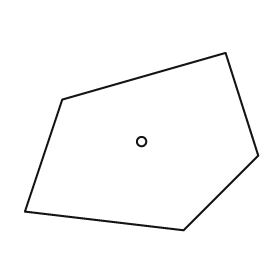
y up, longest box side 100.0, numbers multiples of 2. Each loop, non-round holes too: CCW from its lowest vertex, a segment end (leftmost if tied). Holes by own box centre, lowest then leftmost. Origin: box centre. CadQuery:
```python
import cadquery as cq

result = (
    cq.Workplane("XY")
    .moveTo(18.0, -38.0)
    .lineTo(50.0, -6.0)
    .lineTo(36.0, 38.0)
    .lineTo(-34.0, 18.0)
    .lineTo(-50.0, -30.0)
    .close()
    .moveTo(0.0, 0.0)
    .circle(2.0)
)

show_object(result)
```